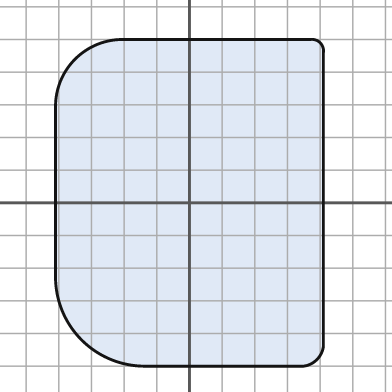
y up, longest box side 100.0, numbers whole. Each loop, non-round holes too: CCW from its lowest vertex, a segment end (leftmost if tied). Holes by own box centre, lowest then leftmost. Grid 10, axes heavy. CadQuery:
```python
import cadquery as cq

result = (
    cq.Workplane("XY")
    .moveTo(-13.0, -50.0)
    .lineTo(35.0, -50.0)
    .threePointArc((39.0, -48.0), (41.0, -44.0))
    .lineTo(41.0, 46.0)
    .threePointArc((40.0, 49.0), (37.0, 50.0))
    .lineTo(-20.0, 50.0)
    .threePointArc((-35.0, 44.0), (-41.0, 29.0))
    .lineTo(-41.0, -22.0)
    .threePointArc((-33.0, -42.0), (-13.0, -50.0))
    .close()
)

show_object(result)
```